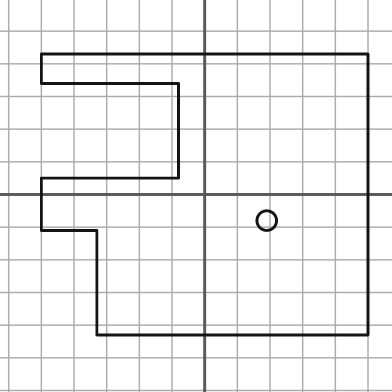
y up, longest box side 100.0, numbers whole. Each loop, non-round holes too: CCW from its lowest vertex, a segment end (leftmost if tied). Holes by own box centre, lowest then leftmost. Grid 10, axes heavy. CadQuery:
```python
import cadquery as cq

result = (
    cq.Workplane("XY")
    .moveTo(-33.0, -43.0)
    .lineTo(50.0, -43.0)
    .lineTo(50.0, 43.0)
    .lineTo(-50.0, 43.0)
    .lineTo(-50.0, 34.0)
    .lineTo(-8.0, 34.0)
    .lineTo(-8.0, 5.0)
    .lineTo(-50.0, 5.0)
    .lineTo(-50.0, -11.0)
    .lineTo(-33.0, -11.0)
    .close()
    .moveTo(19.0, -8.0)
    .circle(3.0)
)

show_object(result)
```